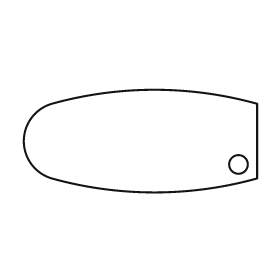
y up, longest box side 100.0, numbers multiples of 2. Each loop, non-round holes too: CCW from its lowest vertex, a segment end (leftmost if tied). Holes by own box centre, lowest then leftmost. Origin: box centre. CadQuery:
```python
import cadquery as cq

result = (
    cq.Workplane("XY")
    .moveTo(-38.0, -16.0)
    .threePointArc((6.0, -22.0), (50.0, -16.0))
    .lineTo(50.0, 16.0)
    .threePointArc((6.0, 22.0), (-38.0, 16.0))
    .threePointArc((-50.0, 0.0), (-38.0, -16.0))
    .close()
    .moveTo(42.0, -10.0)
    .circle(4.0)
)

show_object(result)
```